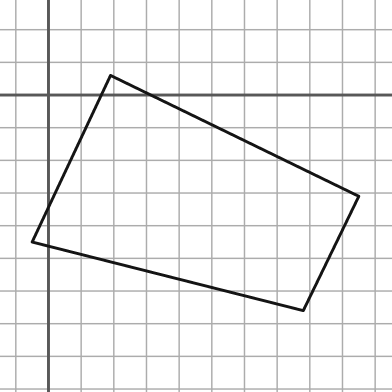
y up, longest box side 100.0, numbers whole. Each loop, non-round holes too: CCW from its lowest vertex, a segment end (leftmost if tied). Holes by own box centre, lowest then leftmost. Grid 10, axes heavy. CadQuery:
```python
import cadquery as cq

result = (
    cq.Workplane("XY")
    .moveTo(78.0, -66.0)
    .lineTo(95.0, -31.0)
    .lineTo(19.0, 6.0)
    .lineTo(-5.0, -45.0)
    .close()
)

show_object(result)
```